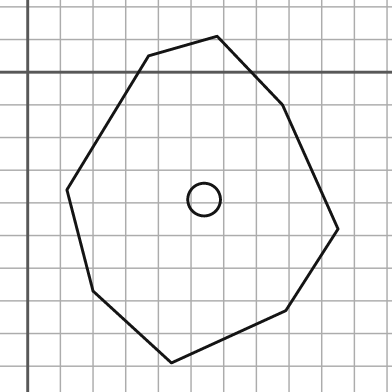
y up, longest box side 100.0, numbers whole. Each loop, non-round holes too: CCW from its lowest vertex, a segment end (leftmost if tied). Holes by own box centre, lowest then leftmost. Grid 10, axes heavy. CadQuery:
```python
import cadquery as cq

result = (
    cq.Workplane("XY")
    .moveTo(44.0, -89.0)
    .lineTo(79.0, -73.0)
    .lineTo(95.0, -48.0)
    .lineTo(78.0, -10.0)
    .lineTo(58.0, 11.0)
    .lineTo(37.0, 5.0)
    .lineTo(12.0, -36.0)
    .lineTo(20.0, -67.0)
    .close()
    .moveTo(54.0, -39.0)
    .circle(5.0)
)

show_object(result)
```